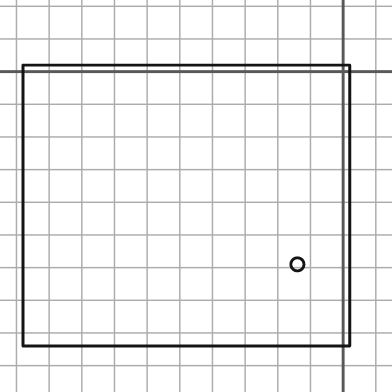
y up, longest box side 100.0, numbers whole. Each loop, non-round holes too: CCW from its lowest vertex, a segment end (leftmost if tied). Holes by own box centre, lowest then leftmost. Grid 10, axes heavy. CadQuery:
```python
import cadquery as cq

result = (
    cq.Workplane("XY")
    .moveTo(-98.0, -84.0)
    .lineTo(2.0, -84.0)
    .lineTo(2.0, 2.0)
    .lineTo(-98.0, 2.0)
    .close()
    .moveTo(-14.0, -59.0)
    .circle(2.0)
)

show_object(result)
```